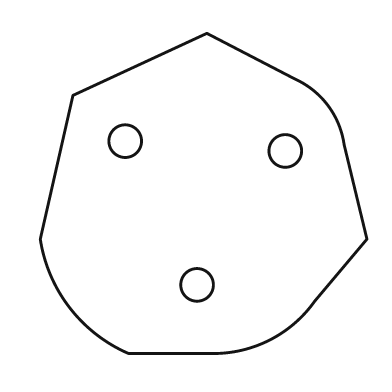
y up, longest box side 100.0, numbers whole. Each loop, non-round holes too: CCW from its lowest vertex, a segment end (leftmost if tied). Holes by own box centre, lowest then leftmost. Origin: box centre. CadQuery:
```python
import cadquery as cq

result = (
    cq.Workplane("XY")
    .moveTo(-23.0, -49.0)
    .lineTo(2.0, -49.0)
    .threePointArc((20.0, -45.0), (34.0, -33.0))
    .lineTo(50.0, -14.0)
    .lineTo(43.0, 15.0)
    .threePointArc((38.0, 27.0), (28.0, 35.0))
    .lineTo(1.0, 49.0)
    .lineTo(-40.0, 30.0)
    .lineTo(-50.0, -14.0)
    .threePointArc((-41.0, -35.0), (-23.0, -49.0))
    .close()
    .moveTo(-2.0, -28.0)
    .circle(5.0)
    .moveTo(25.0, 13.0)
    .circle(5.0)
    .moveTo(-24.0, 16.0)
    .circle(5.0)
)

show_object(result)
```